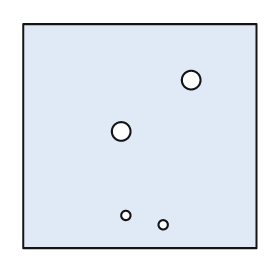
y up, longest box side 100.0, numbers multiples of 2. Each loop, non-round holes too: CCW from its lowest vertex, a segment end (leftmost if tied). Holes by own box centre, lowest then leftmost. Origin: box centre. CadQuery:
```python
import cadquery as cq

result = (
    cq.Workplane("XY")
    .moveTo(-50.0, -48.0)
    .lineTo(50.0, -48.0)
    .lineTo(50.0, 48.0)
    .lineTo(-50.0, 48.0)
    .close()
    .moveTo(10.0, -38.0)
    .circle(2.0)
    .moveTo(-6.0, -34.0)
    .circle(2.0)
    .moveTo(-8.0, 2.0)
    .circle(4.0)
    .moveTo(22.0, 24.0)
    .circle(4.0)
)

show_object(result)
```